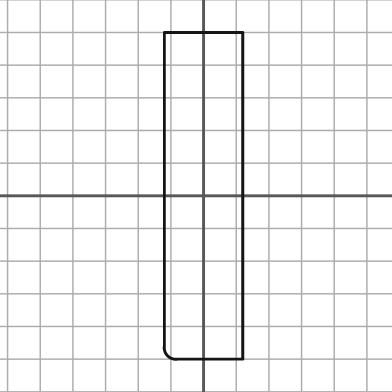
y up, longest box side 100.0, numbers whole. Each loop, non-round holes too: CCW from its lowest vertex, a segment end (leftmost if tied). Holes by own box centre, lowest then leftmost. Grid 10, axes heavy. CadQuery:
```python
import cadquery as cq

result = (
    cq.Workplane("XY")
    .moveTo(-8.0, -50.0)
    .lineTo(12.0, -50.0)
    .lineTo(12.0, 50.0)
    .lineTo(-12.0, 50.0)
    .lineTo(-12.0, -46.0)
    .threePointArc((-11.0, -49.0), (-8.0, -50.0))
    .close()
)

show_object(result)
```